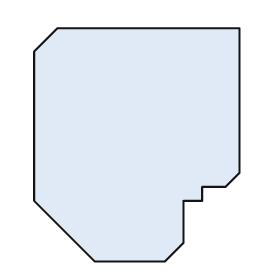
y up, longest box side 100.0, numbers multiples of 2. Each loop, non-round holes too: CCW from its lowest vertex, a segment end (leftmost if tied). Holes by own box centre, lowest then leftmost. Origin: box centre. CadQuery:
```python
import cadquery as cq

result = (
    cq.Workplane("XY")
    .moveTo(-18.0, -50.0)
    .lineTo(12.0, -50.0)
    .lineTo(20.0, -42.0)
    .lineTo(20.0, -24.0)
    .lineTo(28.0, -24.0)
    .lineTo(28.0, -18.0)
    .lineTo(38.0, -18.0)
    .lineTo(44.0, -12.0)
    .lineTo(44.0, 50.0)
    .lineTo(-34.0, 50.0)
    .lineTo(-44.0, 40.0)
    .lineTo(-44.0, -24.0)
    .close()
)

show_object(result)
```